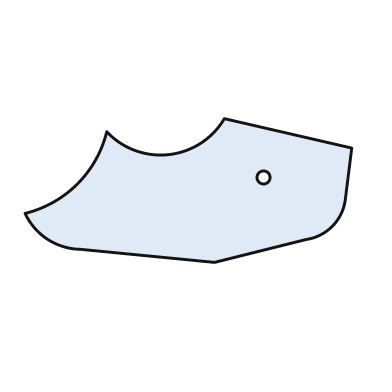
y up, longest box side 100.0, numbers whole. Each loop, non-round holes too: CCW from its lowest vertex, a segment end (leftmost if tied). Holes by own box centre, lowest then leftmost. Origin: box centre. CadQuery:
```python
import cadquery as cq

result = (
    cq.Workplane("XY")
    .moveTo(8.0, -22.0)
    .lineTo(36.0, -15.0)
    .threePointArc((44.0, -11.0), (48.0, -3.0))
    .lineTo(50.0, 13.0)
    .lineTo(11.0, 22.0)
    .threePointArc((-6.0, 11.0), (-25.0, 18.0))
    .threePointArc((-34.0, 2.0), (-50.0, -7.0))
    .threePointArc((-43.0, -15.0), (-33.0, -18.0))
    .close()
    .moveTo(23.0, 4.0)
    .circle(2.0)
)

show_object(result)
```